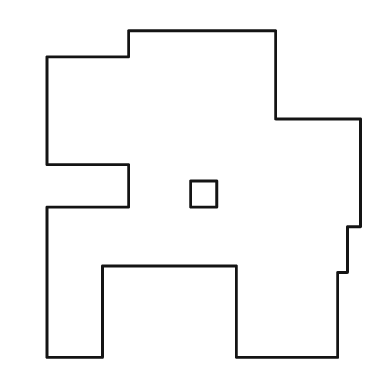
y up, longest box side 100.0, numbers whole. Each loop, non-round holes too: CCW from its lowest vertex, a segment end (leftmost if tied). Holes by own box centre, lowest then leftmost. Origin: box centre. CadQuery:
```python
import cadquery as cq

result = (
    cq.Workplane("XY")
    .moveTo(-48.0, -50.0)
    .lineTo(-31.0, -50.0)
    .lineTo(-31.0, -22.0)
    .lineTo(10.0, -22.0)
    .lineTo(10.0, -50.0)
    .lineTo(41.0, -50.0)
    .lineTo(41.0, -24.0)
    .lineTo(44.0, -24.0)
    .lineTo(44.0, -10.0)
    .lineTo(48.0, -10.0)
    .lineTo(48.0, 23.0)
    .lineTo(22.0, 23.0)
    .lineTo(22.0, 50.0)
    .lineTo(-23.0, 50.0)
    .lineTo(-23.0, 42.0)
    .lineTo(-48.0, 42.0)
    .lineTo(-48.0, 9.0)
    .lineTo(-23.0, 9.0)
    .lineTo(-23.0, -4.0)
    .lineTo(-48.0, -4.0)
    .close()
    .moveTo(-4.0, -4.0)
    .lineTo(4.0, -4.0)
    .lineTo(4.0, 4.0)
    .lineTo(-4.0, 4.0)
    .close()
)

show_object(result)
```